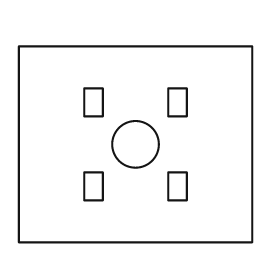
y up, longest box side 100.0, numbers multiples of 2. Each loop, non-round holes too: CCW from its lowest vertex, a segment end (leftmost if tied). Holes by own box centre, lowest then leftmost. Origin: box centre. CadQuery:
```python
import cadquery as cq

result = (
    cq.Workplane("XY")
    .moveTo(-50.0, -42.0)
    .lineTo(50.0, -42.0)
    .lineTo(50.0, 42.0)
    .lineTo(-50.0, 42.0)
    .close()
    .moveTo(-22.0, -24.0)
    .lineTo(-14.0, -24.0)
    .lineTo(-14.0, -12.0)
    .lineTo(-22.0, -12.0)
    .close()
    .moveTo(14.0, -24.0)
    .lineTo(22.0, -24.0)
    .lineTo(22.0, -12.0)
    .lineTo(14.0, -12.0)
    .close()
    .moveTo(0.0, 0.0)
    .circle(10.0)
    .moveTo(-22.0, 12.0)
    .lineTo(-14.0, 12.0)
    .lineTo(-14.0, 24.0)
    .lineTo(-22.0, 24.0)
    .close()
    .moveTo(14.0, 12.0)
    .lineTo(22.0, 12.0)
    .lineTo(22.0, 24.0)
    .lineTo(14.0, 24.0)
    .close()
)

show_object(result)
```